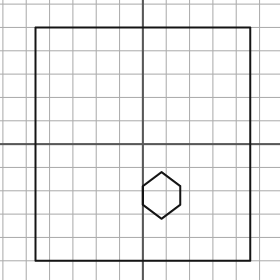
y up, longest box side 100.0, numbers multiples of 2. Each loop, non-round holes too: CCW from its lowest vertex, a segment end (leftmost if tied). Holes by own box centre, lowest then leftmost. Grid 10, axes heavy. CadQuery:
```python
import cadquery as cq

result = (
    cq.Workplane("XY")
    .moveTo(-46.0, -50.0)
    .lineTo(46.0, -50.0)
    .lineTo(46.0, 50.0)
    .lineTo(-46.0, 50.0)
    .close()
    .moveTo(8.0, -32.0)
    .lineTo(16.0, -26.0)
    .lineTo(16.0, -18.0)
    .lineTo(8.0, -12.0)
    .lineTo(0.0, -18.0)
    .lineTo(0.0, -26.0)
    .close()
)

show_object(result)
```